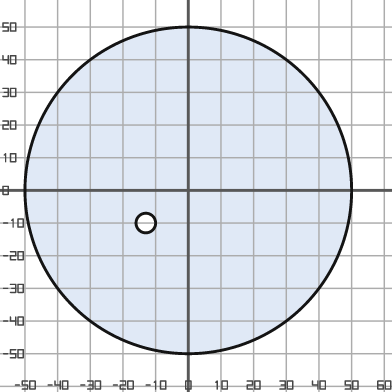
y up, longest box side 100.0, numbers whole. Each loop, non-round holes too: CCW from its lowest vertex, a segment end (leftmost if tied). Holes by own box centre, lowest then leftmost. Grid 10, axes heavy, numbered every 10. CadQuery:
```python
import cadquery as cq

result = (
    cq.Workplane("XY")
    .moveTo(0.0, 0.0)
    .circle(50.0)
    .moveTo(-13.0, -10.0)
    .circle(3.0)
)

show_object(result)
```